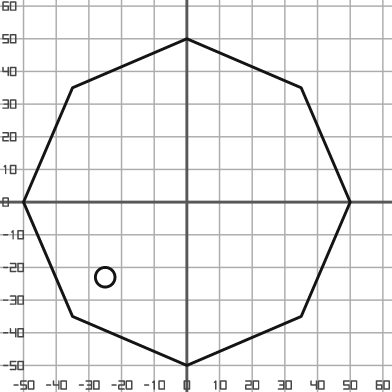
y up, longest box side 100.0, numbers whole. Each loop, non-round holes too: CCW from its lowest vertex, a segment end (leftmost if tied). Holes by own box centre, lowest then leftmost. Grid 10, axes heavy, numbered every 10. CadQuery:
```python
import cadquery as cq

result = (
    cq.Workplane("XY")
    .moveTo(0.0, -50.0)
    .lineTo(35.0, -35.0)
    .lineTo(50.0, 0.0)
    .lineTo(35.0, 35.0)
    .lineTo(0.0, 50.0)
    .lineTo(-35.0, 35.0)
    .lineTo(-50.0, 0.0)
    .lineTo(-35.0, -35.0)
    .close()
    .moveTo(-25.0, -23.0)
    .circle(3.0)
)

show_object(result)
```